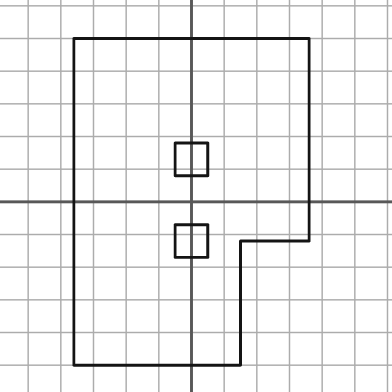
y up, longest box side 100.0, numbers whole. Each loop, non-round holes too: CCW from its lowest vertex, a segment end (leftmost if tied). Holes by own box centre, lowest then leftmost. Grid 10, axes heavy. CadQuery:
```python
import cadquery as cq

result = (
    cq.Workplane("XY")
    .moveTo(-36.0, -50.0)
    .lineTo(15.0, -50.0)
    .lineTo(15.0, -12.0)
    .lineTo(36.0, -12.0)
    .lineTo(36.0, 50.0)
    .lineTo(-36.0, 50.0)
    .close()
    .moveTo(-5.0, -17.0)
    .lineTo(5.0, -17.0)
    .lineTo(5.0, -7.0)
    .lineTo(-5.0, -7.0)
    .close()
    .moveTo(-5.0, 8.0)
    .lineTo(5.0, 8.0)
    .lineTo(5.0, 18.0)
    .lineTo(-5.0, 18.0)
    .close()
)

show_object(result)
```